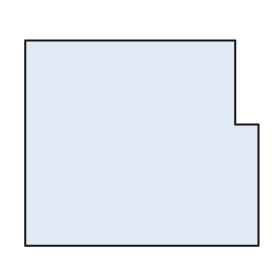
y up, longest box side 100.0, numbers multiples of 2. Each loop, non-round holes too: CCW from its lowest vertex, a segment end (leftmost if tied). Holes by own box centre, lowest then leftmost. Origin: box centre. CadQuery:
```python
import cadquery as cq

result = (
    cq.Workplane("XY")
    .moveTo(-50.0, -44.0)
    .lineTo(50.0, -44.0)
    .lineTo(50.0, 8.0)
    .lineTo(40.0, 8.0)
    .lineTo(40.0, 44.0)
    .lineTo(-50.0, 44.0)
    .close()
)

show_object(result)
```